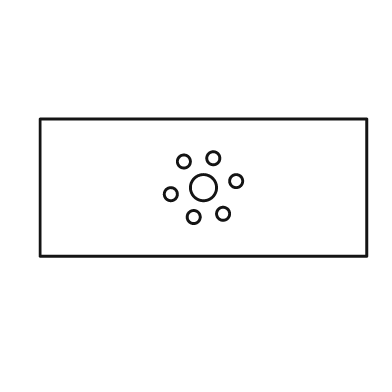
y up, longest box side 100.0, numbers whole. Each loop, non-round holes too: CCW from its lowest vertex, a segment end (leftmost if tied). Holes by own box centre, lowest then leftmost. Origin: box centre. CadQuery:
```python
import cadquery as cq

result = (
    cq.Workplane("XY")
    .moveTo(-50.0, -21.0)
    .lineTo(50.0, -21.0)
    .lineTo(50.0, 21.0)
    .lineTo(-50.0, 21.0)
    .close()
    .moveTo(-3.0, -9.0)
    .circle(2.0)
    .moveTo(6.0, -8.0)
    .circle(2.0)
    .moveTo(-10.0, -2.0)
    .circle(2.0)
    .moveTo(0.0, 0.0)
    .circle(4.0)
    .moveTo(10.0, 2.0)
    .circle(2.0)
    .moveTo(-6.0, 8.0)
    .circle(2.0)
    .moveTo(3.0, 9.0)
    .circle(2.0)
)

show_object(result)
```